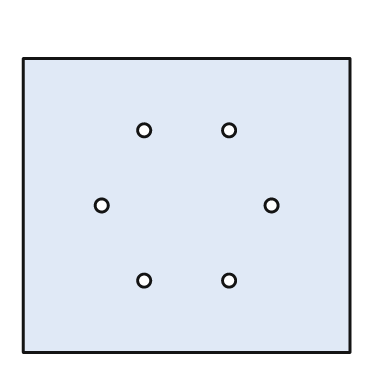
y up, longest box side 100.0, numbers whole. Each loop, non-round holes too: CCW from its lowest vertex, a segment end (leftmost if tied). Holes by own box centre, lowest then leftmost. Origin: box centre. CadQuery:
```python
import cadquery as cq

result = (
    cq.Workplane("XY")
    .moveTo(-50.0, -45.0)
    .lineTo(50.0, -45.0)
    .lineTo(50.0, 45.0)
    .lineTo(-50.0, 45.0)
    .close()
    .moveTo(-13.0, -23.0)
    .circle(2.0)
    .moveTo(13.0, -23.0)
    .circle(2.0)
    .moveTo(-26.0, 0.0)
    .circle(2.0)
    .moveTo(26.0, 0.0)
    .circle(2.0)
    .moveTo(-13.0, 23.0)
    .circle(2.0)
    .moveTo(13.0, 23.0)
    .circle(2.0)
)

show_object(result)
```